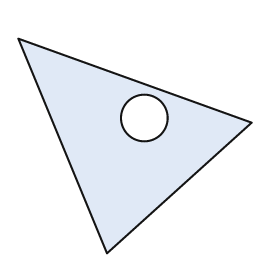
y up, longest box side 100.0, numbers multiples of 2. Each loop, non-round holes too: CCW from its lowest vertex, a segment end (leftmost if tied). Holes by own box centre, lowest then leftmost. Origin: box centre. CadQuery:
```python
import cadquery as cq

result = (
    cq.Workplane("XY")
    .moveTo(-12.0, -46.0)
    .lineTo(50.0, 10.0)
    .lineTo(-50.0, 46.0)
    .close()
    .moveTo(4.0, 12.0)
    .circle(10.0)
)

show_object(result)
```